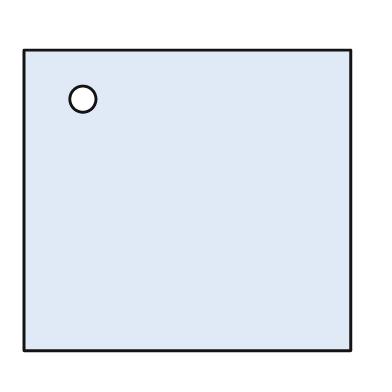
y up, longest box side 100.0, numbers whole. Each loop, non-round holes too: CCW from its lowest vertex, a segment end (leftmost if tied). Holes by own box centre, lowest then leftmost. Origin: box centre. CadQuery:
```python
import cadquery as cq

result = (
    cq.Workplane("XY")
    .moveTo(-50.0, -46.0)
    .lineTo(50.0, -46.0)
    .lineTo(50.0, 46.0)
    .lineTo(-50.0, 46.0)
    .close()
    .moveTo(-32.0, 31.0)
    .circle(4.0)
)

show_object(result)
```